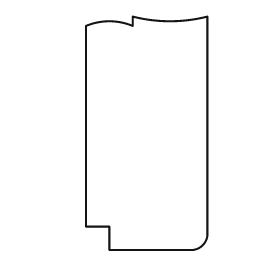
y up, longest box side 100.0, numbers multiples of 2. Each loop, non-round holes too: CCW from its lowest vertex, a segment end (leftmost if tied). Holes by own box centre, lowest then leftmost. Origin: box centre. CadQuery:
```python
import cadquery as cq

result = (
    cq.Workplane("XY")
    .moveTo(-16.0, -50.0)
    .lineTo(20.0, -50.0)
    .threePointArc((24.0, -48.0), (26.0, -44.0))
    .lineTo(26.0, 50.0)
    .threePointArc((10.0, 48.0), (-6.0, 50.0))
    .lineTo(-6.0, 46.0)
    .threePointArc((-16.0, 48.0), (-26.0, 46.0))
    .lineTo(-26.0, -40.0)
    .lineTo(-16.0, -40.0)
    .close()
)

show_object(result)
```